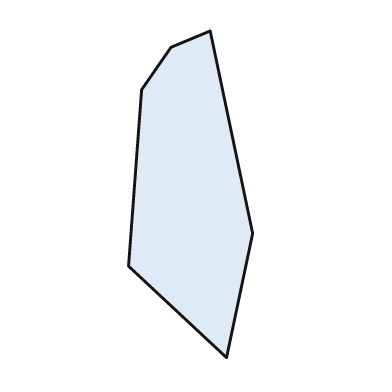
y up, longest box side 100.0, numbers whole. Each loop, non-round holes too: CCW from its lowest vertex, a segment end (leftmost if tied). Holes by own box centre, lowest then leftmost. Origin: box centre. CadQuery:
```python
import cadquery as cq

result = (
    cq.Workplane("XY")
    .moveTo(11.0, -50.0)
    .lineTo(19.0, -12.0)
    .lineTo(6.0, 50.0)
    .lineTo(-6.0, 45.0)
    .lineTo(-15.0, 32.0)
    .lineTo(-19.0, -22.0)
    .close()
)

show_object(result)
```